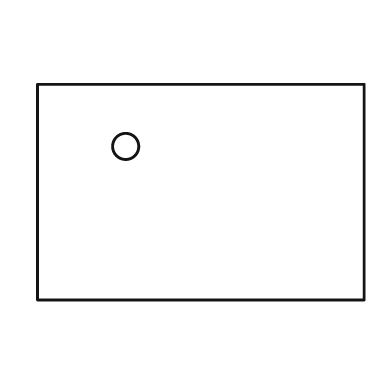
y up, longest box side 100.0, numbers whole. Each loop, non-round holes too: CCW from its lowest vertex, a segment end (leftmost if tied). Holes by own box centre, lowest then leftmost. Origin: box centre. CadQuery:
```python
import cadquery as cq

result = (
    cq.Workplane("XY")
    .moveTo(-50.0, -33.0)
    .lineTo(50.0, -33.0)
    .lineTo(50.0, 33.0)
    .lineTo(-50.0, 33.0)
    .close()
    .moveTo(-23.0, 14.0)
    .circle(4.0)
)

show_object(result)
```